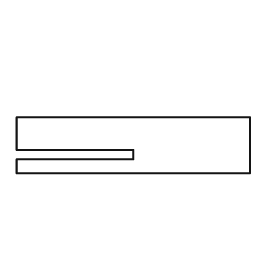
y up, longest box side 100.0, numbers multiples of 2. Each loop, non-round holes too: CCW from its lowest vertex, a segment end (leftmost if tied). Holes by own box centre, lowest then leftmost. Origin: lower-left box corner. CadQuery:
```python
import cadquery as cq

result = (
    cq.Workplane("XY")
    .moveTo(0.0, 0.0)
    .lineTo(100.0, 0.0)
    .lineTo(100.0, 24.0)
    .lineTo(0.0, 24.0)
    .lineTo(0.0, 10.0)
    .lineTo(50.0, 10.0)
    .lineTo(50.0, 6.0)
    .lineTo(0.0, 6.0)
    .close()
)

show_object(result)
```